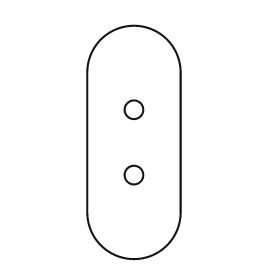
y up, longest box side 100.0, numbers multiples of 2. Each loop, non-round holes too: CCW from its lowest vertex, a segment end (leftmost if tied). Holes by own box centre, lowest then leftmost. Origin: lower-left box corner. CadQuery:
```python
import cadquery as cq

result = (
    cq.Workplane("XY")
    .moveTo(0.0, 20.0)
    .threePointArc((20.0, 0.0), (40.0, 20.0))
    .lineTo(40.0, 80.0)
    .threePointArc((20.0, 100.0), (0.0, 80.0))
    .close()
    .moveTo(20.0, 36.0)
    .circle(4.0)
    .moveTo(20.0, 64.0)
    .circle(4.0)
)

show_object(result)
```